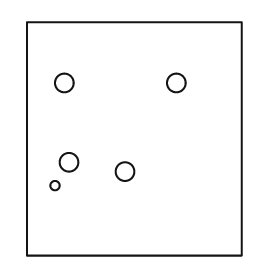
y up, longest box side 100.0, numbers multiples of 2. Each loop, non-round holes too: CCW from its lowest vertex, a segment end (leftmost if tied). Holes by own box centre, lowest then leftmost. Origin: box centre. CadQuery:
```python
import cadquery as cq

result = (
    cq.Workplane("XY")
    .moveTo(-46.0, -50.0)
    .lineTo(46.0, -50.0)
    .lineTo(46.0, 50.0)
    .lineTo(-46.0, 50.0)
    .close()
    .moveTo(-34.0, -20.0)
    .circle(2.0)
    .moveTo(-4.0, -14.0)
    .circle(4.0)
    .moveTo(-28.0, -10.0)
    .circle(4.0)
    .moveTo(-30.0, 24.0)
    .circle(4.0)
    .moveTo(18.0, 24.0)
    .circle(4.0)
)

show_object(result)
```